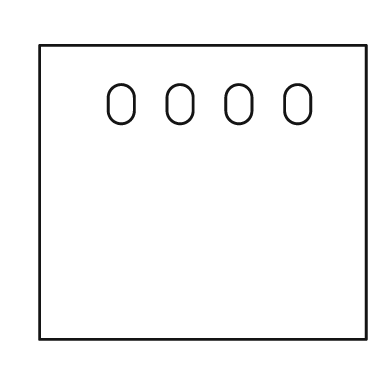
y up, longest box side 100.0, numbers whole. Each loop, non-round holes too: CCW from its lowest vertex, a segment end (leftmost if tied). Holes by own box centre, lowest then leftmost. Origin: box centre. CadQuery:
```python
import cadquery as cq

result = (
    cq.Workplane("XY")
    .moveTo(-50.0, -45.0)
    .lineTo(50.0, -45.0)
    .lineTo(50.0, 45.0)
    .lineTo(-50.0, 45.0)
    .close()
    .moveTo(-29.0, 25.0)
    .threePointArc((-25.0, 21.0), (-21.0, 25.0))
    .lineTo(-21.0, 29.0)
    .threePointArc((-25.0, 33.0), (-29.0, 29.0))
    .close()
    .moveTo(-11.0, 25.0)
    .threePointArc((-7.0, 21.0), (-3.0, 25.0))
    .lineTo(-3.0, 29.0)
    .threePointArc((-7.0, 33.0), (-11.0, 29.0))
    .close()
    .moveTo(7.0, 25.0)
    .threePointArc((11.0, 21.0), (15.0, 25.0))
    .lineTo(15.0, 29.0)
    .threePointArc((11.0, 33.0), (7.0, 29.0))
    .close()
    .moveTo(25.0, 25.0)
    .threePointArc((29.0, 21.0), (33.0, 25.0))
    .lineTo(33.0, 29.0)
    .threePointArc((29.0, 33.0), (25.0, 29.0))
    .close()
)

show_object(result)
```